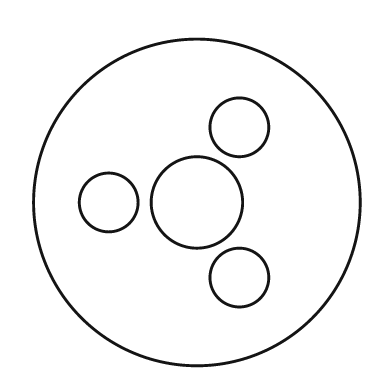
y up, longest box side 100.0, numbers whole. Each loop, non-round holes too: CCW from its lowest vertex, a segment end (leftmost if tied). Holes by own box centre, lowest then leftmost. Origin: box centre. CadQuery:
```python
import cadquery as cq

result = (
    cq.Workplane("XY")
    .moveTo(0.0, 0.0)
    .circle(50.0)
    .moveTo(13.0, -23.0)
    .circle(9.0)
    .moveTo(-27.0, 0.0)
    .circle(9.0)
    .moveTo(0.0, 0.0)
    .circle(14.0)
    .moveTo(13.0, 23.0)
    .circle(9.0)
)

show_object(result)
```